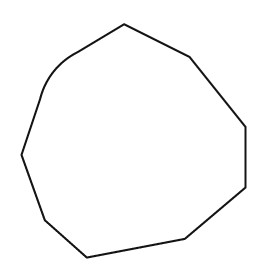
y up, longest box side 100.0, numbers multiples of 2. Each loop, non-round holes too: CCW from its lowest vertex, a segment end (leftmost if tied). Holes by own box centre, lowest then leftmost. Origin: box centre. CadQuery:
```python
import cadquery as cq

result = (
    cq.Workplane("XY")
    .moveTo(-20.0, -50.0)
    .lineTo(22.0, -42.0)
    .lineTo(48.0, -20.0)
    .lineTo(48.0, 6.0)
    .lineTo(24.0, 36.0)
    .lineTo(-4.0, 50.0)
    .lineTo(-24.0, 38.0)
    .threePointArc((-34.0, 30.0), (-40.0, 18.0))
    .lineTo(-48.0, -6.0)
    .lineTo(-38.0, -34.0)
    .close()
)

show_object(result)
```